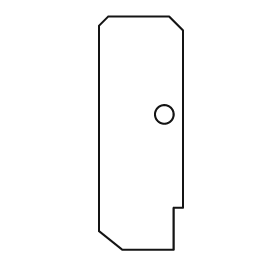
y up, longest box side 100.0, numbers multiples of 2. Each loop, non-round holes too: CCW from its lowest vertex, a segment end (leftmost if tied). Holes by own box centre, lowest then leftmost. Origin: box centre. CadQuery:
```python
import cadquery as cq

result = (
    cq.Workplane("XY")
    .moveTo(-8.0, -50.0)
    .lineTo(14.0, -50.0)
    .lineTo(14.0, -32.0)
    .lineTo(18.0, -32.0)
    .lineTo(18.0, 44.0)
    .lineTo(12.0, 50.0)
    .lineTo(-14.0, 50.0)
    .lineTo(-18.0, 46.0)
    .lineTo(-18.0, -42.0)
    .close()
    .moveTo(10.0, 8.0)
    .circle(4.0)
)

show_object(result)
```